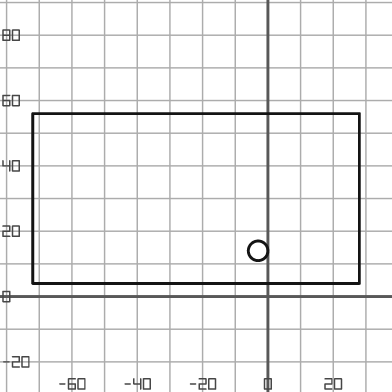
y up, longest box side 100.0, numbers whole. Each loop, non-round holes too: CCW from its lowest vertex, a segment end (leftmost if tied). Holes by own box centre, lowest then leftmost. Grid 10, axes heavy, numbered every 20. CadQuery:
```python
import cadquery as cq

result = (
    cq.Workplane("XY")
    .moveTo(-72.0, 4.0)
    .lineTo(28.0, 4.0)
    .lineTo(28.0, 56.0)
    .lineTo(-72.0, 56.0)
    .close()
    .moveTo(-3.0, 14.0)
    .circle(3.0)
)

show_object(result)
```